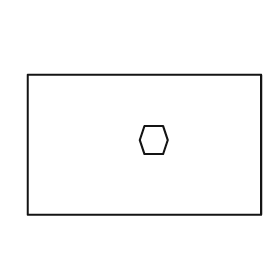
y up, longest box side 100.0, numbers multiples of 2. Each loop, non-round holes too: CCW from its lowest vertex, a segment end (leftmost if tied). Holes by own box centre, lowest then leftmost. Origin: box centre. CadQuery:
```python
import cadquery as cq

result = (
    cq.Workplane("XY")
    .moveTo(-50.0, -30.0)
    .lineTo(50.0, -30.0)
    .lineTo(50.0, 30.0)
    .lineTo(-50.0, 30.0)
    .close()
    .moveTo(0.0, -4.0)
    .lineTo(8.0, -4.0)
    .lineTo(10.0, 2.0)
    .lineTo(8.0, 8.0)
    .lineTo(0.0, 8.0)
    .lineTo(-2.0, 2.0)
    .close()
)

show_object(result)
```